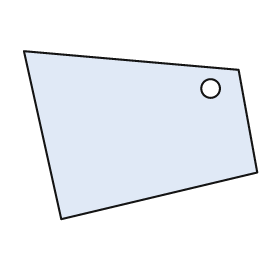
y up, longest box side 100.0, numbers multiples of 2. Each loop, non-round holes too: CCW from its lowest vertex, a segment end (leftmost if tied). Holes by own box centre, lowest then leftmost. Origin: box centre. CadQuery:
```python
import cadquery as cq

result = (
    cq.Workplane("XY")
    .moveTo(-34.0, -36.0)
    .lineTo(50.0, -16.0)
    .lineTo(42.0, 28.0)
    .lineTo(-50.0, 36.0)
    .close()
    .moveTo(30.0, 20.0)
    .circle(4.0)
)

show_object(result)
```